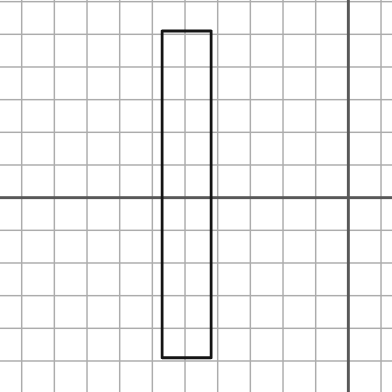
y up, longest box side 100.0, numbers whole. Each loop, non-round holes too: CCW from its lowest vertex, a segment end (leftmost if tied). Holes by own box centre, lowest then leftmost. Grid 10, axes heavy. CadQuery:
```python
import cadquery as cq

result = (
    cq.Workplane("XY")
    .moveTo(-57.0, -49.0)
    .lineTo(-42.0, -49.0)
    .lineTo(-42.0, 51.0)
    .lineTo(-57.0, 51.0)
    .close()
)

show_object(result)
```